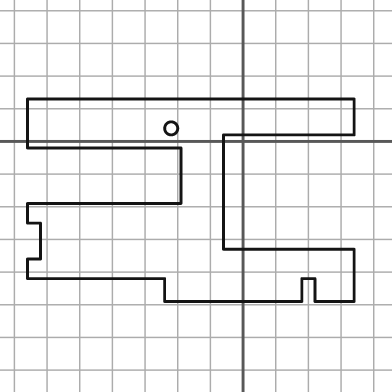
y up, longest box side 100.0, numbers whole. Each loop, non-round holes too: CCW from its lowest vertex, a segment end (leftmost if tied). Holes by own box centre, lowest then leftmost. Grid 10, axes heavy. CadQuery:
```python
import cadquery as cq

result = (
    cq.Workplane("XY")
    .moveTo(-24.0, -49.0)
    .lineTo(18.0, -49.0)
    .lineTo(18.0, -42.0)
    .lineTo(22.0, -42.0)
    .lineTo(22.0, -49.0)
    .lineTo(34.0, -49.0)
    .lineTo(34.0, -33.0)
    .lineTo(-6.0, -33.0)
    .lineTo(-6.0, 2.0)
    .lineTo(34.0, 2.0)
    .lineTo(34.0, 13.0)
    .lineTo(-66.0, 13.0)
    .lineTo(-66.0, -2.0)
    .lineTo(-19.0, -2.0)
    .lineTo(-19.0, -19.0)
    .lineTo(-66.0, -19.0)
    .lineTo(-66.0, -25.0)
    .lineTo(-62.0, -25.0)
    .lineTo(-62.0, -36.0)
    .lineTo(-66.0, -36.0)
    .lineTo(-66.0, -42.0)
    .lineTo(-24.0, -42.0)
    .close()
    .moveTo(-22.0, 4.0)
    .circle(2.0)
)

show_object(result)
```